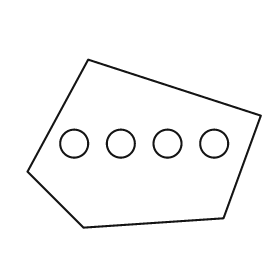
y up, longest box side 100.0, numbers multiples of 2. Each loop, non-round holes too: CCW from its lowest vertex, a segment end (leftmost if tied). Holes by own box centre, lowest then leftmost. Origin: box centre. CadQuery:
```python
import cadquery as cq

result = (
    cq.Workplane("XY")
    .moveTo(-26.0, -36.0)
    .lineTo(34.0, -32.0)
    .lineTo(50.0, 12.0)
    .lineTo(-24.0, 36.0)
    .lineTo(-50.0, -12.0)
    .close()
    .moveTo(-30.0, 0.0)
    .circle(6.0)
    .moveTo(-10.0, 0.0)
    .circle(6.0)
    .moveTo(10.0, 0.0)
    .circle(6.0)
    .moveTo(30.0, 0.0)
    .circle(6.0)
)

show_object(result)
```